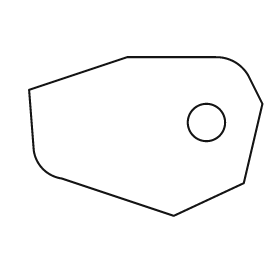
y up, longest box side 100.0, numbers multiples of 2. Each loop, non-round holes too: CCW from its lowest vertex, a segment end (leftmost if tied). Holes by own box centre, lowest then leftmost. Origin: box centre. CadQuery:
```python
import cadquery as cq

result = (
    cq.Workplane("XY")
    .moveTo(12.0, -34.0)
    .lineTo(42.0, -20.0)
    .lineTo(50.0, 14.0)
    .lineTo(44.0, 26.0)
    .threePointArc((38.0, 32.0), (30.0, 34.0))
    .lineTo(-8.0, 34.0)
    .lineTo(-50.0, 20.0)
    .lineTo(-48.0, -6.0)
    .threePointArc((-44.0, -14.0), (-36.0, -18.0))
    .close()
    .moveTo(26.0, 6.0)
    .circle(8.0)
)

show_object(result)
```